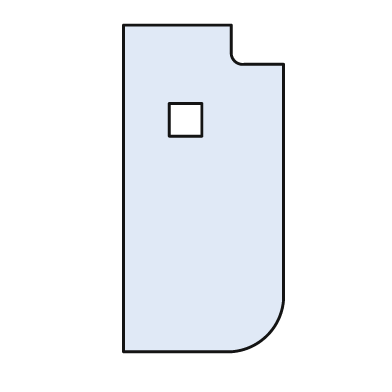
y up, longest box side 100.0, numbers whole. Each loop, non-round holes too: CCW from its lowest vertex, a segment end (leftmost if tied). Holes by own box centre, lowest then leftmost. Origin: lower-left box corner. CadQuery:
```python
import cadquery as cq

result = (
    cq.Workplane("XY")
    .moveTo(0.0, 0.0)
    .lineTo(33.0, 0.0)
    .threePointArc((44.0, 5.0), (49.0, 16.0))
    .lineTo(49.0, 88.0)
    .lineTo(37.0, 88.0)
    .threePointArc((34.0, 89.0), (33.0, 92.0))
    .lineTo(33.0, 100.0)
    .lineTo(0.0, 100.0)
    .close()
    .moveTo(14.0, 66.0)
    .lineTo(24.0, 66.0)
    .lineTo(24.0, 76.0)
    .lineTo(14.0, 76.0)
    .close()
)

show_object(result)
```